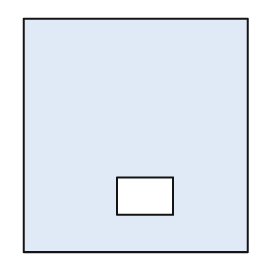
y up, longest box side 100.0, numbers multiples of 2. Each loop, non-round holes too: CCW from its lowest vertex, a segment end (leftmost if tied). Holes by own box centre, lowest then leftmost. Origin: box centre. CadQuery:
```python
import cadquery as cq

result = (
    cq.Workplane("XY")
    .moveTo(-48.0, -50.0)
    .lineTo(48.0, -50.0)
    .lineTo(48.0, 50.0)
    .lineTo(-48.0, 50.0)
    .close()
    .moveTo(-8.0, -34.0)
    .lineTo(16.0, -34.0)
    .lineTo(16.0, -18.0)
    .lineTo(-8.0, -18.0)
    .close()
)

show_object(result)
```